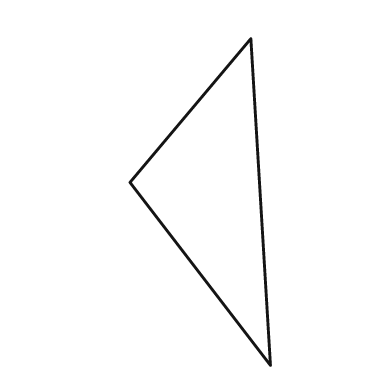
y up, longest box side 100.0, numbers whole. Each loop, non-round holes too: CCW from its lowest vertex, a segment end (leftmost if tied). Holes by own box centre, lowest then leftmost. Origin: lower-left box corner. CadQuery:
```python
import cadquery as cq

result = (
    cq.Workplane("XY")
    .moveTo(43.0, 0.0)
    .lineTo(37.0, 100.0)
    .lineTo(0.0, 56.0)
    .close()
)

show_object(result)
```